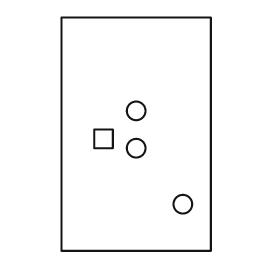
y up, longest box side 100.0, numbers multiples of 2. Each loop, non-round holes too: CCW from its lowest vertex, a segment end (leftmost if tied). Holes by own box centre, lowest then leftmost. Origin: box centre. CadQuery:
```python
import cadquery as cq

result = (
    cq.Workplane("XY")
    .moveTo(-32.0, -50.0)
    .lineTo(32.0, -50.0)
    .lineTo(32.0, 50.0)
    .lineTo(-32.0, 50.0)
    .close()
    .moveTo(20.0, -30.0)
    .circle(4.0)
    .moveTo(0.0, -6.0)
    .circle(4.0)
    .moveTo(-18.0, -6.0)
    .lineTo(-10.0, -6.0)
    .lineTo(-10.0, 2.0)
    .lineTo(-18.0, 2.0)
    .close()
    .moveTo(0.0, 10.0)
    .circle(4.0)
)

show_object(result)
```